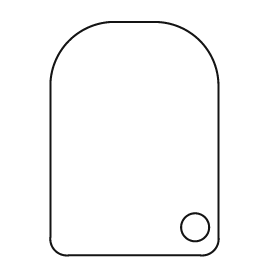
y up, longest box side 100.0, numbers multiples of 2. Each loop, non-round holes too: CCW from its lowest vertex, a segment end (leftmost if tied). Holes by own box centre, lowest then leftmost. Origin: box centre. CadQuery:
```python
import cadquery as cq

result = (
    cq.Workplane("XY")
    .moveTo(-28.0, -50.0)
    .lineTo(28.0, -50.0)
    .threePointArc((34.0, -48.0), (36.0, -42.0))
    .lineTo(36.0, 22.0)
    .threePointArc((28.0, 42.0), (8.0, 50.0))
    .lineTo(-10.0, 50.0)
    .threePointArc((-28.0, 42.0), (-36.0, 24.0))
    .lineTo(-36.0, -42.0)
    .threePointArc((-34.0, -48.0), (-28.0, -50.0))
    .close()
    .moveTo(26.0, -38.0)
    .circle(6.0)
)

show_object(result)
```